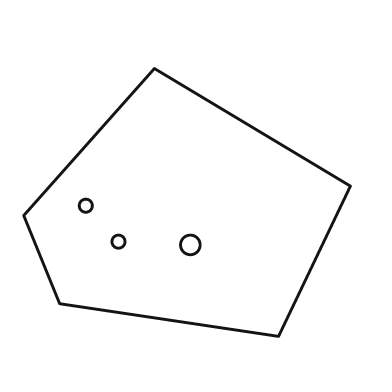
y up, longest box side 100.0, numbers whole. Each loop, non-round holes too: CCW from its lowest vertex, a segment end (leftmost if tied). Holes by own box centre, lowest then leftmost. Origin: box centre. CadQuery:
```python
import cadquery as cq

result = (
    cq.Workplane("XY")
    .moveTo(28.0, -41.0)
    .lineTo(50.0, 5.0)
    .lineTo(-10.0, 41.0)
    .lineTo(-50.0, -4.0)
    .lineTo(-39.0, -31.0)
    .close()
    .moveTo(1.0, -13.0)
    .circle(3.0)
    .moveTo(-21.0, -12.0)
    .circle(2.0)
    .moveTo(-31.0, -1.0)
    .circle(2.0)
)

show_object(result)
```